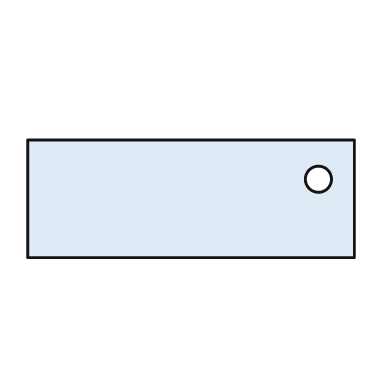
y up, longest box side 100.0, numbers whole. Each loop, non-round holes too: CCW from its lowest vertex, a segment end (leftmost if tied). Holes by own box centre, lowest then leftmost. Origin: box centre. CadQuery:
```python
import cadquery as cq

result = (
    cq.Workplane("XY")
    .moveTo(-50.0, -18.0)
    .lineTo(50.0, -18.0)
    .lineTo(50.0, 18.0)
    .lineTo(-50.0, 18.0)
    .close()
    .moveTo(39.0, 6.0)
    .circle(4.0)
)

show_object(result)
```